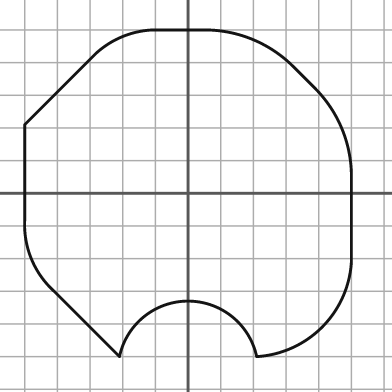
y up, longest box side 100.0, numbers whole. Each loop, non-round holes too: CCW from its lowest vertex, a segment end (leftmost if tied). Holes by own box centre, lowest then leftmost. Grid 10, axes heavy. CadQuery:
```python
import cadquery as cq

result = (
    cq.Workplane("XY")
    .moveTo(-21.0, -50.0)
    .threePointArc((0.0, -33.0), (21.0, -50.0))
    .threePointArc((41.0, -41.0), (50.0, -21.0))
    .lineTo(50.0, 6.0)
    .threePointArc((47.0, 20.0), (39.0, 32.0))
    .lineTo(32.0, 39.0)
    .threePointArc((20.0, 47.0), (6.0, 50.0))
    .lineTo(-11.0, 50.0)
    .threePointArc((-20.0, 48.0), (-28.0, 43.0))
    .lineTo(-50.0, 21.0)
    .lineTo(-50.0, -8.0)
    .threePointArc((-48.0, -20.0), (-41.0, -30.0))
    .close()
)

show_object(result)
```